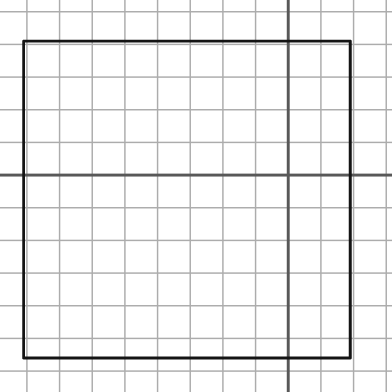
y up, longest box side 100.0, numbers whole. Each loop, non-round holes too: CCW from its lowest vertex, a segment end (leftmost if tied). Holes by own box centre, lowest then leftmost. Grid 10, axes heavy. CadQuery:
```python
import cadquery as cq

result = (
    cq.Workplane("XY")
    .moveTo(-81.0, -56.0)
    .lineTo(19.0, -56.0)
    .lineTo(19.0, 41.0)
    .lineTo(-81.0, 41.0)
    .close()
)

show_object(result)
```